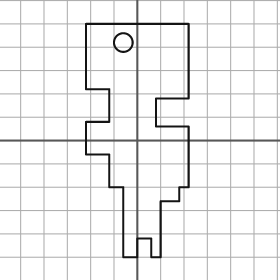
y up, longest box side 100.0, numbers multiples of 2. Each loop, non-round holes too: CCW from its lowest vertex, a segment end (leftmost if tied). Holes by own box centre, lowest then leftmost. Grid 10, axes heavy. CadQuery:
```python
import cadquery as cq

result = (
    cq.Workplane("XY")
    .moveTo(-6.0, -50.0)
    .lineTo(0.0, -50.0)
    .lineTo(0.0, -42.0)
    .lineTo(6.0, -42.0)
    .lineTo(6.0, -50.0)
    .lineTo(10.0, -50.0)
    .lineTo(10.0, -26.0)
    .lineTo(18.0, -26.0)
    .lineTo(18.0, -20.0)
    .lineTo(22.0, -20.0)
    .lineTo(22.0, 6.0)
    .lineTo(8.0, 6.0)
    .lineTo(8.0, 18.0)
    .lineTo(22.0, 18.0)
    .lineTo(22.0, 50.0)
    .lineTo(-22.0, 50.0)
    .lineTo(-22.0, 22.0)
    .lineTo(-12.0, 22.0)
    .lineTo(-12.0, 8.0)
    .lineTo(-22.0, 8.0)
    .lineTo(-22.0, -6.0)
    .lineTo(-12.0, -6.0)
    .lineTo(-12.0, -20.0)
    .lineTo(-6.0, -20.0)
    .close()
    .moveTo(-6.0, 42.0)
    .circle(4.0)
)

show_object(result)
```